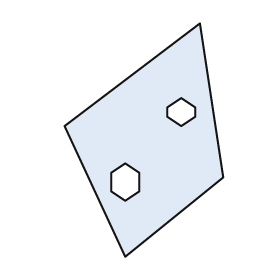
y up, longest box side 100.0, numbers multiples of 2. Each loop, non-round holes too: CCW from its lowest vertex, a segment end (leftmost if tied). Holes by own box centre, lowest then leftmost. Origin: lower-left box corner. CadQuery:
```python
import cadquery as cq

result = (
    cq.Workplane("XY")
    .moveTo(26.0, 0.0)
    .lineTo(68.0, 34.0)
    .lineTo(58.0, 100.0)
    .lineTo(0.0, 56.0)
    .close()
    .moveTo(26.0, 24.0)
    .lineTo(32.0, 28.0)
    .lineTo(32.0, 36.0)
    .lineTo(26.0, 40.0)
    .lineTo(20.0, 36.0)
    .lineTo(20.0, 28.0)
    .close()
    .moveTo(50.0, 56.0)
    .lineTo(56.0, 60.0)
    .lineTo(56.0, 64.0)
    .lineTo(50.0, 68.0)
    .lineTo(44.0, 64.0)
    .lineTo(44.0, 60.0)
    .close()
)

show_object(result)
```